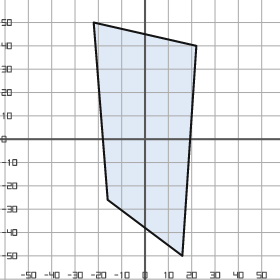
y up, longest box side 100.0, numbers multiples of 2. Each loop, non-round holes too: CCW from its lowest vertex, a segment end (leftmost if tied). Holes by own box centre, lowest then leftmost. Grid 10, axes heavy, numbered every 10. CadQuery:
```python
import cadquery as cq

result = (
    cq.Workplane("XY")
    .moveTo(16.0, -50.0)
    .lineTo(22.0, 40.0)
    .lineTo(-22.0, 50.0)
    .lineTo(-16.0, -26.0)
    .close()
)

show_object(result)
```